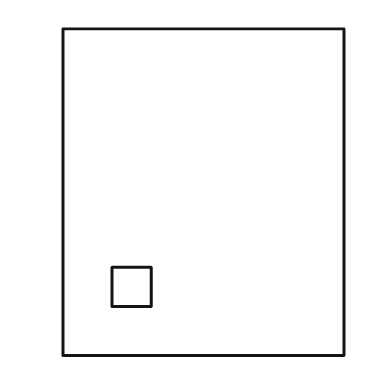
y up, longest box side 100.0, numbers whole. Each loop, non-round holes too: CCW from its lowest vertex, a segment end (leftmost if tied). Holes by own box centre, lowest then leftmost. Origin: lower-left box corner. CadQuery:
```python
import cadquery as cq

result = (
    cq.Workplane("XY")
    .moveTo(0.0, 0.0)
    .lineTo(86.0, 0.0)
    .lineTo(86.0, 100.0)
    .lineTo(0.0, 100.0)
    .close()
    .moveTo(15.0, 15.0)
    .lineTo(27.0, 15.0)
    .lineTo(27.0, 27.0)
    .lineTo(15.0, 27.0)
    .close()
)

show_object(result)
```